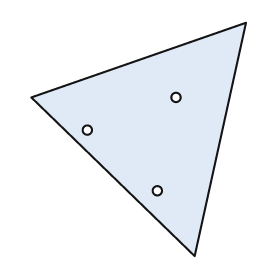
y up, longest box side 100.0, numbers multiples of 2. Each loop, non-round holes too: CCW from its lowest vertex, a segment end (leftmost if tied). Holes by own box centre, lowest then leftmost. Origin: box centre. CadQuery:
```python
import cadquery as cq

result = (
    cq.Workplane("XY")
    .moveTo(24.0, -50.0)
    .lineTo(46.0, 50.0)
    .lineTo(-46.0, 18.0)
    .close()
    .moveTo(8.0, -22.0)
    .circle(2.0)
    .moveTo(-22.0, 4.0)
    .circle(2.0)
    .moveTo(16.0, 18.0)
    .circle(2.0)
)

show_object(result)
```